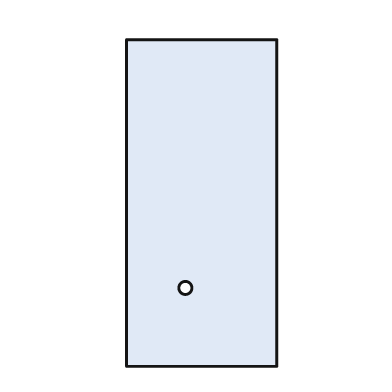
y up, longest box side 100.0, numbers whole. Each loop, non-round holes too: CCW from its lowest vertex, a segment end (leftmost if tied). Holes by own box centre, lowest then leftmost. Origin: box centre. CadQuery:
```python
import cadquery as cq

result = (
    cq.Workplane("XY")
    .moveTo(-23.0, -50.0)
    .lineTo(23.0, -50.0)
    .lineTo(23.0, 50.0)
    .lineTo(-23.0, 50.0)
    .close()
    .moveTo(-5.0, -26.0)
    .circle(2.0)
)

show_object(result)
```